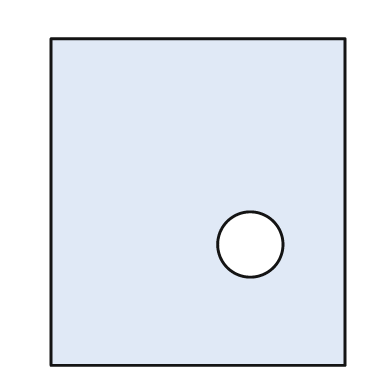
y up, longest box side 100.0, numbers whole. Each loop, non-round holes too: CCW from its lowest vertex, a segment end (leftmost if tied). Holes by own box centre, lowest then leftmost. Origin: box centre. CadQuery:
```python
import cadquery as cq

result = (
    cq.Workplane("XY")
    .moveTo(-45.0, -50.0)
    .lineTo(45.0, -50.0)
    .lineTo(45.0, 50.0)
    .lineTo(-45.0, 50.0)
    .close()
    .moveTo(16.0, -13.0)
    .circle(10.0)
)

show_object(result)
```